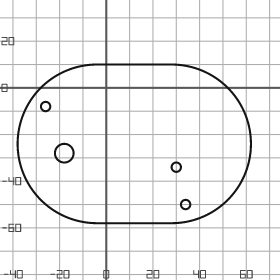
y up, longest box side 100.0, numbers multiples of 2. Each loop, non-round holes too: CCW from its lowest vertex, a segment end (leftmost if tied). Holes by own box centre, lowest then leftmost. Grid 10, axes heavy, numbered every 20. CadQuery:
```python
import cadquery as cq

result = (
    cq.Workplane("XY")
    .moveTo(-4.0, -58.0)
    .lineTo(28.0, -58.0)
    .threePointArc((62.0, -24.0), (28.0, 10.0))
    .lineTo(-4.0, 10.0)
    .threePointArc((-38.0, -24.0), (-4.0, -58.0))
    .close()
    .moveTo(34.0, -50.0)
    .circle(2.0)
    .moveTo(30.0, -34.0)
    .circle(2.0)
    .moveTo(-18.0, -28.0)
    .circle(4.0)
    .moveTo(-26.0, -8.0)
    .circle(2.0)
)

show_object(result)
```